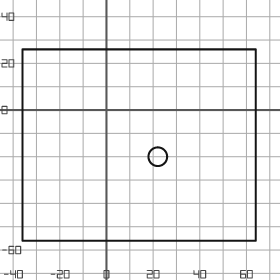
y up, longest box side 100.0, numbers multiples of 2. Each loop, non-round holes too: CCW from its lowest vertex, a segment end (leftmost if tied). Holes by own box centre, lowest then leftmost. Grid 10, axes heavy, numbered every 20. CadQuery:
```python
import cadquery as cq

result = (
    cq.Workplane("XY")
    .moveTo(-36.0, -56.0)
    .lineTo(64.0, -56.0)
    .lineTo(64.0, 26.0)
    .lineTo(-36.0, 26.0)
    .close()
    .moveTo(22.0, -20.0)
    .circle(4.0)
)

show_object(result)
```